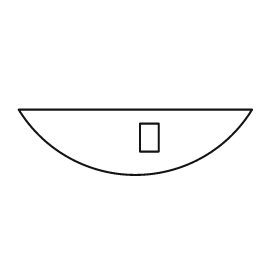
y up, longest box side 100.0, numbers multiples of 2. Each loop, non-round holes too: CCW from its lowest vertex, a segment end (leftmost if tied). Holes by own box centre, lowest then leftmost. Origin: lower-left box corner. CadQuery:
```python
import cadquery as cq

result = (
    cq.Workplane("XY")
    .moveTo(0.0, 28.0)
    .threePointArc((50.0, 0.0), (100.0, 28.0))
    .close()
    .moveTo(52.0, 10.0)
    .lineTo(60.0, 10.0)
    .lineTo(60.0, 22.0)
    .lineTo(52.0, 22.0)
    .close()
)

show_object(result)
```